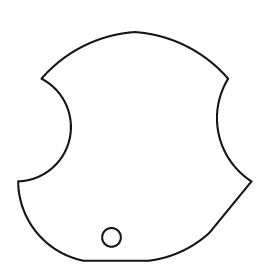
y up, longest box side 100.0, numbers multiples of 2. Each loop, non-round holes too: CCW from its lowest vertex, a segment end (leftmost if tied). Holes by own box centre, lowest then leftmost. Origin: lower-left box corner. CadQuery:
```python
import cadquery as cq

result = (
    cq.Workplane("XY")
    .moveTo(28.0, 0.0)
    .lineTo(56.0, 0.0)
    .threePointArc((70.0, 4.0), (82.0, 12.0))
    .lineTo(100.0, 34.0)
    .threePointArc((86.0, 54.0), (90.0, 78.0))
    .threePointArc((72.0, 92.0), (50.0, 98.0))
    .threePointArc((28.0, 92.0), (10.0, 78.0))
    .threePointArc((22.0, 52.0), (0.0, 34.0))
    .threePointArc((8.0, 12.0), (28.0, 0.0))
    .close()
    .moveTo(40.0, 10.0)
    .circle(4.0)
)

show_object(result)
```